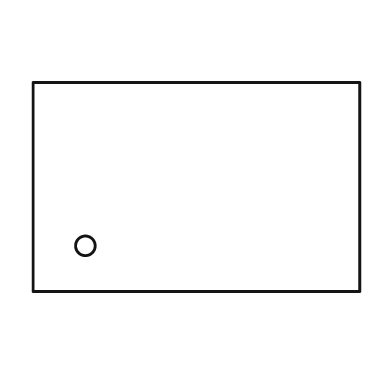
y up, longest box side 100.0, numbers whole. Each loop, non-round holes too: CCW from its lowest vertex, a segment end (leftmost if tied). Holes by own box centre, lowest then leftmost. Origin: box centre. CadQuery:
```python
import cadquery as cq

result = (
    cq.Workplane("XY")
    .moveTo(-50.0, -32.0)
    .lineTo(50.0, -32.0)
    .lineTo(50.0, 32.0)
    .lineTo(-50.0, 32.0)
    .close()
    .moveTo(-34.0, -18.0)
    .circle(3.0)
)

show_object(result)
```